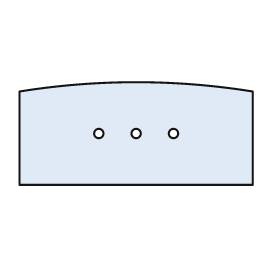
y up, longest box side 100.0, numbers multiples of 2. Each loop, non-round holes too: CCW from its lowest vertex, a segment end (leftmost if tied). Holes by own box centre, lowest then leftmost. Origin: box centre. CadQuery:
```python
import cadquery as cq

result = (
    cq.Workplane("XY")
    .moveTo(-50.0, -22.0)
    .lineTo(50.0, -22.0)
    .lineTo(50.0, 18.0)
    .threePointArc((0.0, 22.0), (-50.0, 18.0))
    .close()
    .moveTo(-16.0, 0.0)
    .circle(2.0)
    .moveTo(0.0, 0.0)
    .circle(2.0)
    .moveTo(16.0, 0.0)
    .circle(2.0)
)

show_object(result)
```